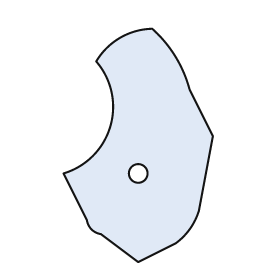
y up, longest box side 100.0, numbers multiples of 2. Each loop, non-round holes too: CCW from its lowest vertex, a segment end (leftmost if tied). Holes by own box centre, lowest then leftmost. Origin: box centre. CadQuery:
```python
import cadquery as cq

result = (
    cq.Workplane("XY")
    .moveTo(0.0, -50.0)
    .lineTo(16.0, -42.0)
    .threePointArc((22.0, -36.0), (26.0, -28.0))
    .lineTo(32.0, 4.0)
    .lineTo(22.0, 24.0)
    .threePointArc((16.0, 38.0), (6.0, 50.0))
    .threePointArc((-8.0, 46.0), (-18.0, 36.0))
    .threePointArc((-12.0, 8.0), (-32.0, -12.0))
    .lineTo(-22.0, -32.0)
    .threePointArc((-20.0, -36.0), (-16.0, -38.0))
    .close()
    .moveTo(0.0, -12.0)
    .circle(4.0)
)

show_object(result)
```